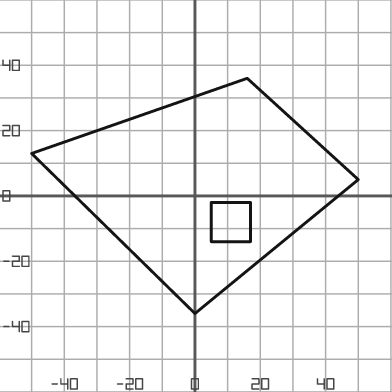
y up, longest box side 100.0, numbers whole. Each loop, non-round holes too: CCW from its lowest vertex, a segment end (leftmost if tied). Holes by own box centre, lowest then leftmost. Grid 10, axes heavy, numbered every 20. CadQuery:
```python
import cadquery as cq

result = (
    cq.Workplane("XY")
    .moveTo(0.0, -36.0)
    .lineTo(50.0, 5.0)
    .lineTo(16.0, 36.0)
    .lineTo(-50.0, 13.0)
    .close()
    .moveTo(5.0, -14.0)
    .lineTo(17.0, -14.0)
    .lineTo(17.0, -2.0)
    .lineTo(5.0, -2.0)
    .close()
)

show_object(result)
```